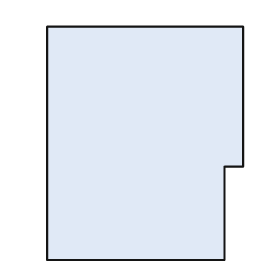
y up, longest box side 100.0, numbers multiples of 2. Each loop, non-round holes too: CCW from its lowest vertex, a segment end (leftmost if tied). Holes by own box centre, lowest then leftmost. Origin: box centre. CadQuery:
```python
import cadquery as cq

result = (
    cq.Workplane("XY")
    .moveTo(-42.0, -50.0)
    .lineTo(34.0, -50.0)
    .lineTo(34.0, -10.0)
    .lineTo(42.0, -10.0)
    .lineTo(42.0, 50.0)
    .lineTo(-42.0, 50.0)
    .close()
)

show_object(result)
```